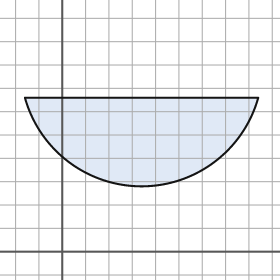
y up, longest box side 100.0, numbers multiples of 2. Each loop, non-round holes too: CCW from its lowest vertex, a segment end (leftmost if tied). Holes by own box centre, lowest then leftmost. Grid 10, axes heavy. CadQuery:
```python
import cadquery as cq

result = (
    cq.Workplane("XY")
    .moveTo(-16.0, 66.0)
    .threePointArc((34.0, 28.0), (84.0, 66.0))
    .close()
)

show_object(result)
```